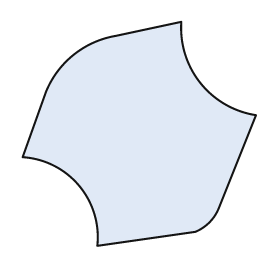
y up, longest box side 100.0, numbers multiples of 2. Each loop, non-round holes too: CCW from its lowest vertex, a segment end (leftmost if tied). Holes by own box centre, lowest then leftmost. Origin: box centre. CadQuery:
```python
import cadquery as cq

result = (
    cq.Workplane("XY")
    .moveTo(-18.0, -48.0)
    .lineTo(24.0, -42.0)
    .threePointArc((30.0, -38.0), (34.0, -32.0))
    .lineTo(50.0, 8.0)
    .threePointArc((26.0, 22.0), (18.0, 48.0))
    .lineTo(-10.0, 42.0)
    .threePointArc((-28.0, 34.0), (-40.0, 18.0))
    .lineTo(-50.0, -10.0)
    .threePointArc((-26.0, -22.0), (-18.0, -48.0))
    .close()
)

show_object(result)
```